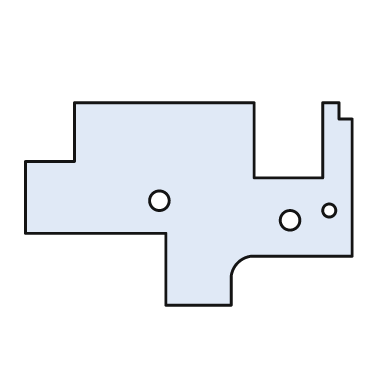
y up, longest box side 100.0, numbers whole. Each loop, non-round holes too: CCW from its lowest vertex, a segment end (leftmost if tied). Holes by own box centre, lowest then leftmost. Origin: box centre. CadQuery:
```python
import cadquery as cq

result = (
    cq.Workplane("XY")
    .moveTo(-7.0, -31.0)
    .lineTo(13.0, -31.0)
    .lineTo(13.0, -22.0)
    .threePointArc((15.0, -18.0), (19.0, -16.0))
    .lineTo(50.0, -16.0)
    .lineTo(50.0, 26.0)
    .lineTo(46.0, 26.0)
    .lineTo(46.0, 31.0)
    .lineTo(41.0, 31.0)
    .lineTo(41.0, 8.0)
    .lineTo(20.0, 8.0)
    .lineTo(20.0, 31.0)
    .lineTo(-35.0, 31.0)
    .lineTo(-35.0, 13.0)
    .lineTo(-50.0, 13.0)
    .lineTo(-50.0, -9.0)
    .lineTo(-7.0, -9.0)
    .close()
    .moveTo(31.0, -5.0)
    .circle(3.0)
    .moveTo(43.0, -2.0)
    .circle(2.0)
    .moveTo(-9.0, 1.0)
    .circle(3.0)
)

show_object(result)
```